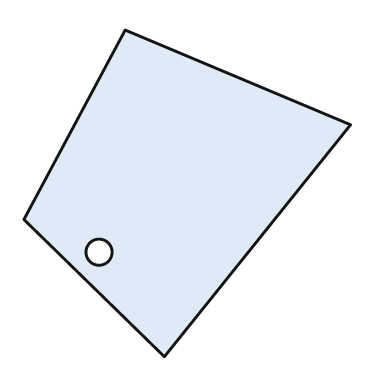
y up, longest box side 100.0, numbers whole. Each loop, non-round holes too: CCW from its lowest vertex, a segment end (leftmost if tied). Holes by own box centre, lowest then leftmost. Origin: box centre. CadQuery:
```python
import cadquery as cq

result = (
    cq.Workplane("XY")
    .moveTo(-7.0, -50.0)
    .lineTo(50.0, 21.0)
    .lineTo(-19.0, 50.0)
    .lineTo(-50.0, -8.0)
    .close()
    .moveTo(-27.0, -18.0)
    .circle(4.0)
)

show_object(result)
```